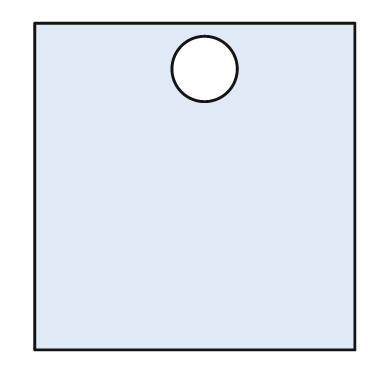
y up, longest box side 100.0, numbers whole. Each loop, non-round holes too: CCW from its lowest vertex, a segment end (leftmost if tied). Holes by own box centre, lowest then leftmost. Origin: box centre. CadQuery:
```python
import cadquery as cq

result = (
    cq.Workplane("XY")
    .moveTo(-49.0, -50.0)
    .lineTo(49.0, -50.0)
    .lineTo(49.0, 50.0)
    .lineTo(-49.0, 50.0)
    .close()
    .moveTo(3.0, 36.0)
    .circle(10.0)
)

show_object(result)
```